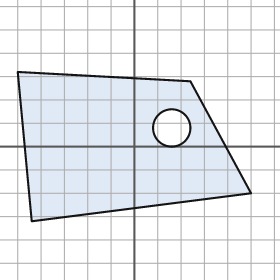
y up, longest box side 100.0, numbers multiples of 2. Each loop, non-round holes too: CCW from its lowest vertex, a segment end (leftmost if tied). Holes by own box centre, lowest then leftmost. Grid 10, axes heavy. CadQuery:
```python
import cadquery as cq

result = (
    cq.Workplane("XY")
    .moveTo(-44.0, -32.0)
    .lineTo(50.0, -20.0)
    .lineTo(24.0, 28.0)
    .lineTo(-50.0, 32.0)
    .close()
    .moveTo(16.0, 8.0)
    .circle(8.0)
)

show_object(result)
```